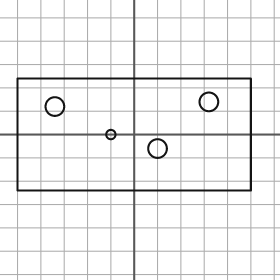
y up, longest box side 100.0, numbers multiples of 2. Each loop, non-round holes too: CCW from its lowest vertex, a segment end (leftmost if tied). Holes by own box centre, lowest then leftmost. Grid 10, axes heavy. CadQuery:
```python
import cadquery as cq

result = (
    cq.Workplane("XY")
    .moveTo(-50.0, -24.0)
    .lineTo(50.0, -24.0)
    .lineTo(50.0, 24.0)
    .lineTo(-50.0, 24.0)
    .close()
    .moveTo(10.0, -6.0)
    .circle(4.0)
    .moveTo(-10.0, 0.0)
    .circle(2.0)
    .moveTo(-34.0, 12.0)
    .circle(4.0)
    .moveTo(32.0, 14.0)
    .circle(4.0)
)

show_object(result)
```